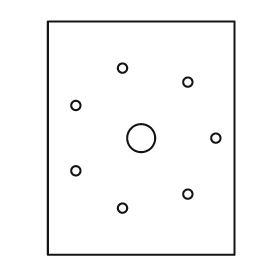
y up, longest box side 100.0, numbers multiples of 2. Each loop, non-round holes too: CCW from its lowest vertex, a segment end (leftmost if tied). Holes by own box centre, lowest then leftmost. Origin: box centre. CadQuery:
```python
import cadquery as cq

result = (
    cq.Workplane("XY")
    .moveTo(-40.0, -50.0)
    .lineTo(40.0, -50.0)
    .lineTo(40.0, 50.0)
    .lineTo(-40.0, 50.0)
    .close()
    .moveTo(-8.0, -30.0)
    .circle(2.0)
    .moveTo(20.0, -24.0)
    .circle(2.0)
    .moveTo(-28.0, -14.0)
    .circle(2.0)
    .moveTo(0.0, 0.0)
    .circle(6.0)
    .moveTo(32.0, 0.0)
    .circle(2.0)
    .moveTo(-28.0, 14.0)
    .circle(2.0)
    .moveTo(20.0, 24.0)
    .circle(2.0)
    .moveTo(-8.0, 30.0)
    .circle(2.0)
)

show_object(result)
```